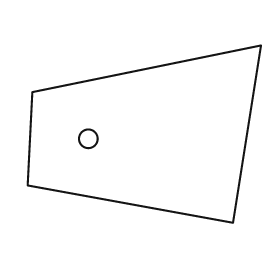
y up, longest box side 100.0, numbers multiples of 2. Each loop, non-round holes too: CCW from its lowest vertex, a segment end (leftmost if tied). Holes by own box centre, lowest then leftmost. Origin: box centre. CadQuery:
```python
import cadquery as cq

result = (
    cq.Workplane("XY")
    .moveTo(38.0, -38.0)
    .lineTo(50.0, 38.0)
    .lineTo(-48.0, 18.0)
    .lineTo(-50.0, -22.0)
    .close()
    .moveTo(-24.0, -2.0)
    .circle(4.0)
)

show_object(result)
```